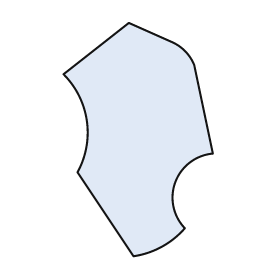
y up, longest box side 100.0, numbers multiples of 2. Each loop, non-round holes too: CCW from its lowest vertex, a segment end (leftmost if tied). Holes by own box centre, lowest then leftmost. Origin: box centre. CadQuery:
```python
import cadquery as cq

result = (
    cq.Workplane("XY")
    .moveTo(-2.0, -50.0)
    .threePointArc((10.0, -46.0), (20.0, -38.0))
    .threePointArc((16.0, -18.0), (32.0, -6.0))
    .lineTo(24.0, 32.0)
    .threePointArc((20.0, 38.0), (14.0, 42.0))
    .lineTo(-4.0, 50.0)
    .lineTo(-32.0, 28.0)
    .threePointArc((-22.0, 8.0), (-26.0, -14.0))
    .close()
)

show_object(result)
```